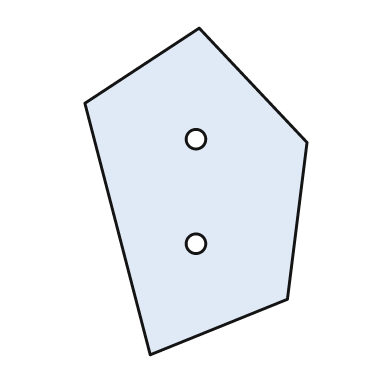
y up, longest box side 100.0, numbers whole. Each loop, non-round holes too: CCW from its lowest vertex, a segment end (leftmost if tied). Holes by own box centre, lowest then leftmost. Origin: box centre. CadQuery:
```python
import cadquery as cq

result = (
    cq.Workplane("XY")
    .moveTo(-14.0, -50.0)
    .lineTo(28.0, -33.0)
    .lineTo(34.0, 15.0)
    .lineTo(1.0, 50.0)
    .lineTo(-34.0, 27.0)
    .close()
    .moveTo(0.0, -16.0)
    .circle(3.0)
    .moveTo(0.0, 16.0)
    .circle(3.0)
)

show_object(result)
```